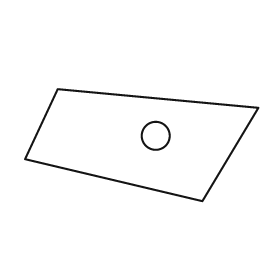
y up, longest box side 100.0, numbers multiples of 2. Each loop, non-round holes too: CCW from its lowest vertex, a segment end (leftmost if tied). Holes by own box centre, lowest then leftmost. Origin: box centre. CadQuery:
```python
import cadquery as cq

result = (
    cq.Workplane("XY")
    .moveTo(26.0, -24.0)
    .lineTo(50.0, 16.0)
    .lineTo(-36.0, 24.0)
    .lineTo(-50.0, -6.0)
    .close()
    .moveTo(6.0, 4.0)
    .circle(6.0)
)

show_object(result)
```